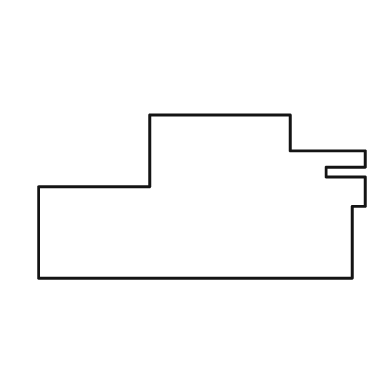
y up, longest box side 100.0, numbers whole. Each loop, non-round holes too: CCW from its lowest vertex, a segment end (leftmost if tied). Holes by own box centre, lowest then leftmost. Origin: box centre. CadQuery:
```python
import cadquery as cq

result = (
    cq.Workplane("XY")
    .moveTo(-50.0, -25.0)
    .lineTo(46.0, -25.0)
    .lineTo(46.0, -3.0)
    .lineTo(50.0, -3.0)
    .lineTo(50.0, 6.0)
    .lineTo(38.0, 6.0)
    .lineTo(38.0, 9.0)
    .lineTo(50.0, 9.0)
    .lineTo(50.0, 14.0)
    .lineTo(27.0, 14.0)
    .lineTo(27.0, 25.0)
    .lineTo(-16.0, 25.0)
    .lineTo(-16.0, 3.0)
    .lineTo(-50.0, 3.0)
    .close()
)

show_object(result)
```